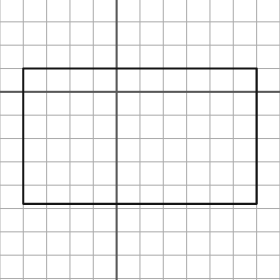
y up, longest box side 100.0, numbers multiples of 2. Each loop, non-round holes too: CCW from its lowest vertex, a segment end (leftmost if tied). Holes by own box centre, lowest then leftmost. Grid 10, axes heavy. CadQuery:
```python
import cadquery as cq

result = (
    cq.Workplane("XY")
    .moveTo(-40.0, -48.0)
    .lineTo(60.0, -48.0)
    .lineTo(60.0, 10.0)
    .lineTo(-40.0, 10.0)
    .close()
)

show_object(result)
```